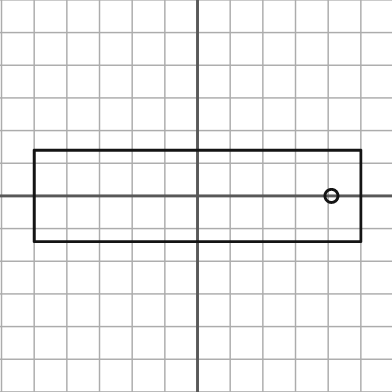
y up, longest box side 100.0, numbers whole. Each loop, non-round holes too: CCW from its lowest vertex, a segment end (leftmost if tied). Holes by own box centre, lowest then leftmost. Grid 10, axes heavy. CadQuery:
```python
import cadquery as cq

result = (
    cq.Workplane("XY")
    .moveTo(-50.0, -14.0)
    .lineTo(50.0, -14.0)
    .lineTo(50.0, 14.0)
    .lineTo(-50.0, 14.0)
    .close()
    .moveTo(41.0, 0.0)
    .circle(2.0)
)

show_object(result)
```